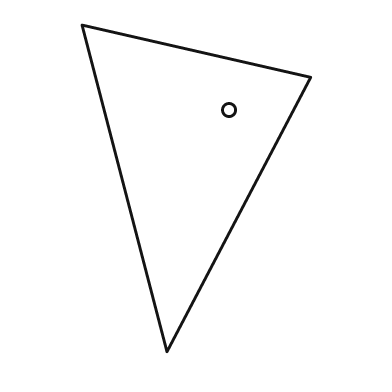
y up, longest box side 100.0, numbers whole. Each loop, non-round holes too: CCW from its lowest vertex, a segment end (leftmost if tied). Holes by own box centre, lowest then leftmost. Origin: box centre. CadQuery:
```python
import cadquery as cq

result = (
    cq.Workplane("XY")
    .moveTo(-9.0, -50.0)
    .lineTo(35.0, 34.0)
    .lineTo(-35.0, 50.0)
    .close()
    .moveTo(10.0, 24.0)
    .circle(2.0)
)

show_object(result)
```